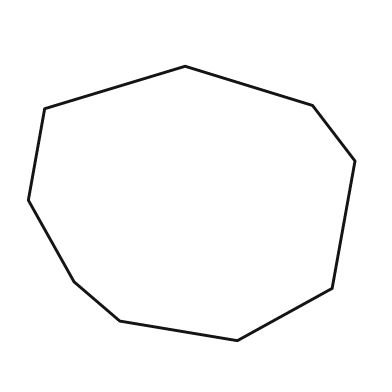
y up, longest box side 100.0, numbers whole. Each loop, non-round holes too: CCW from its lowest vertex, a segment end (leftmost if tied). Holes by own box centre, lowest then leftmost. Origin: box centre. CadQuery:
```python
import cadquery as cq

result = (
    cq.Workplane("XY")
    .moveTo(14.0, -42.0)
    .lineTo(43.0, -26.0)
    .lineTo(50.0, 13.0)
    .lineTo(37.0, 30.0)
    .lineTo(-2.0, 42.0)
    .lineTo(-45.0, 29.0)
    .lineTo(-50.0, 1.0)
    .lineTo(-36.0, -24.0)
    .lineTo(-22.0, -36.0)
    .close()
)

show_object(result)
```